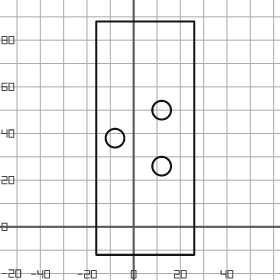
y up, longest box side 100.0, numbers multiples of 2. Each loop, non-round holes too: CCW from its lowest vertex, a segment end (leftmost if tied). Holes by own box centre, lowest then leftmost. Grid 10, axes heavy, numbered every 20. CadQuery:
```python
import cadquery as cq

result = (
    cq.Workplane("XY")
    .moveTo(-16.0, -12.0)
    .lineTo(26.0, -12.0)
    .lineTo(26.0, 88.0)
    .lineTo(-16.0, 88.0)
    .close()
    .moveTo(12.0, 26.0)
    .circle(4.0)
    .moveTo(-8.0, 38.0)
    .circle(4.0)
    .moveTo(12.0, 50.0)
    .circle(4.0)
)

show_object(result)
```